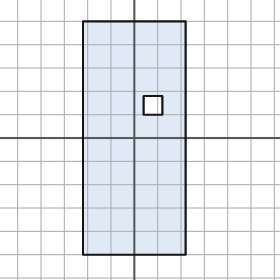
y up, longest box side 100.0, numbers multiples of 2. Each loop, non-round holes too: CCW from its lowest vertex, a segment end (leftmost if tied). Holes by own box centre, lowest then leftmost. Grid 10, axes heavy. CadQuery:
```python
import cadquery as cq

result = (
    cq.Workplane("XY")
    .moveTo(-22.0, -50.0)
    .lineTo(22.0, -50.0)
    .lineTo(22.0, 50.0)
    .lineTo(-22.0, 50.0)
    .close()
    .moveTo(4.0, 10.0)
    .lineTo(12.0, 10.0)
    .lineTo(12.0, 18.0)
    .lineTo(4.0, 18.0)
    .close()
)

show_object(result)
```